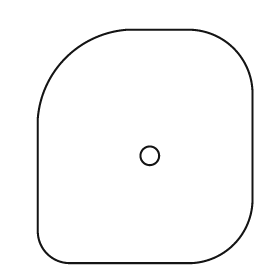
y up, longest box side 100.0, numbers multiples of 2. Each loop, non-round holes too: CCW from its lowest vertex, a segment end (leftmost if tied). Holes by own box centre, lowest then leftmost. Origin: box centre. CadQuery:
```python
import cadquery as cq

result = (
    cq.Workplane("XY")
    .moveTo(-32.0, -50.0)
    .lineTo(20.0, -50.0)
    .threePointArc((38.0, -42.0), (46.0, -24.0))
    .lineTo(46.0, 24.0)
    .threePointArc((38.0, 42.0), (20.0, 50.0))
    .lineTo(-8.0, 50.0)
    .threePointArc((-34.0, 38.0), (-46.0, 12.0))
    .lineTo(-46.0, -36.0)
    .threePointArc((-42.0, -46.0), (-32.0, -50.0))
    .close()
    .moveTo(2.0, -4.0)
    .circle(4.0)
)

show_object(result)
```